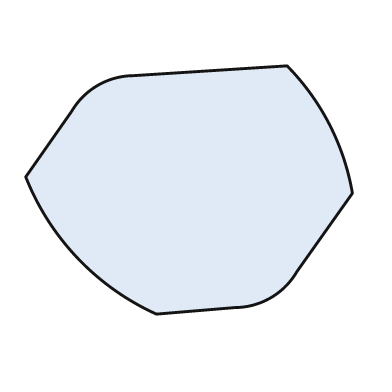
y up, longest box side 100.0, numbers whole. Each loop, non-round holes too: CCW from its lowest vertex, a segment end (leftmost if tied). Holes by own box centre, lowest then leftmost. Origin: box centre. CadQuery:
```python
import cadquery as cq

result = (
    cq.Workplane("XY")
    .moveTo(-10.0, -38.0)
    .lineTo(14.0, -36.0)
    .threePointArc((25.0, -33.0), (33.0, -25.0))
    .lineTo(50.0, -1.0)
    .threePointArc((43.0, 20.0), (30.0, 38.0))
    .lineTo(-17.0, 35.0)
    .threePointArc((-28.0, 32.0), (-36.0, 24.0))
    .lineTo(-50.0, 4.0)
    .threePointArc((-34.0, -21.0), (-10.0, -38.0))
    .close()
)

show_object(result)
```